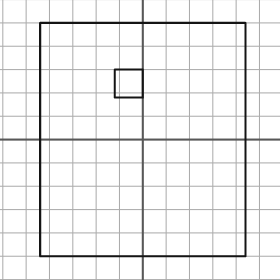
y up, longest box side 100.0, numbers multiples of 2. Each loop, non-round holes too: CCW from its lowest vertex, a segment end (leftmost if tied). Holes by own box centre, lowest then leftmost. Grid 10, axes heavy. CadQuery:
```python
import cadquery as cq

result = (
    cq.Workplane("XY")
    .moveTo(-44.0, -50.0)
    .lineTo(44.0, -50.0)
    .lineTo(44.0, 50.0)
    .lineTo(-44.0, 50.0)
    .close()
    .moveTo(-12.0, 18.0)
    .lineTo(0.0, 18.0)
    .lineTo(0.0, 30.0)
    .lineTo(-12.0, 30.0)
    .close()
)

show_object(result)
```